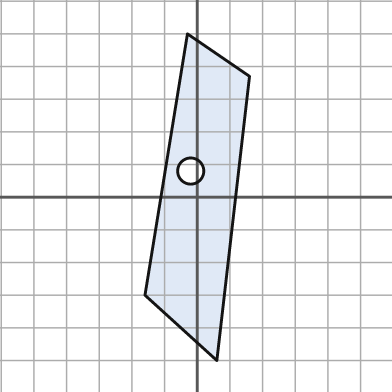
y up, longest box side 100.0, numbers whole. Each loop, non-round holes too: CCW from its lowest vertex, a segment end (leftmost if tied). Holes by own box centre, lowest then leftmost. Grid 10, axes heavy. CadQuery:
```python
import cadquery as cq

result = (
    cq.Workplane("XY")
    .moveTo(6.0, -50.0)
    .lineTo(16.0, 37.0)
    .lineTo(-3.0, 50.0)
    .lineTo(-16.0, -30.0)
    .close()
    .moveTo(-2.0, 8.0)
    .circle(4.0)
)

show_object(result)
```